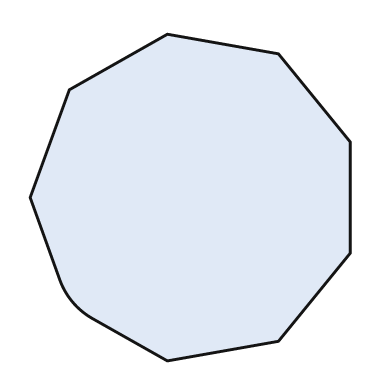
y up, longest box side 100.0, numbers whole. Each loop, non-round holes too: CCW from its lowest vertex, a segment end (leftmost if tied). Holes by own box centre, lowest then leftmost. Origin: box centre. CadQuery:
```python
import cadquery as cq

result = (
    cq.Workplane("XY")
    .moveTo(-7.0, -50.0)
    .lineTo(27.0, -44.0)
    .lineTo(49.0, -17.0)
    .lineTo(49.0, 17.0)
    .lineTo(27.0, 44.0)
    .lineTo(-7.0, 50.0)
    .lineTo(-37.0, 33.0)
    .lineTo(-49.0, 0.0)
    .lineTo(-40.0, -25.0)
    .threePointArc((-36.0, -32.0), (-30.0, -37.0))
    .close()
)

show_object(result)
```